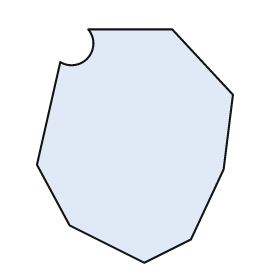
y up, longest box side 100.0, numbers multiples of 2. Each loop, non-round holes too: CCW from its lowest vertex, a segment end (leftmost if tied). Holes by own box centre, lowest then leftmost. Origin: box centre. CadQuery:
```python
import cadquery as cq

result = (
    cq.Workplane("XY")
    .moveTo(4.0, -50.0)
    .lineTo(24.0, -40.0)
    .lineTo(38.0, -10.0)
    .lineTo(42.0, 22.0)
    .lineTo(16.0, 50.0)
    .lineTo(-20.0, 50.0)
    .threePointArc((-20.0, 38.0), (-32.0, 36.0))
    .lineTo(-42.0, -8.0)
    .lineTo(-28.0, -34.0)
    .close()
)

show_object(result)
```